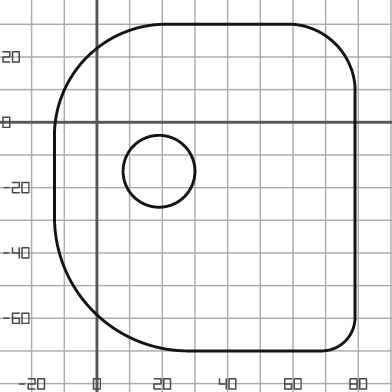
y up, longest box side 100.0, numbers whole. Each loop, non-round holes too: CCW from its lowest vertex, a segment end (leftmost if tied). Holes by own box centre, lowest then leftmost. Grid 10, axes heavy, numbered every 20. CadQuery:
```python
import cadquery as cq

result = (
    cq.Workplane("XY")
    .moveTo(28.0, -70.0)
    .lineTo(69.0, -70.0)
    .threePointArc((76.0, -67.0), (79.0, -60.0))
    .lineTo(79.0, 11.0)
    .threePointArc((73.0, 24.0), (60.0, 30.0))
    .lineTo(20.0, 30.0)
    .threePointArc((-3.0, 20.0), (-13.0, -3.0))
    .lineTo(-13.0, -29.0)
    .threePointArc((-1.0, -58.0), (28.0, -70.0))
    .close()
    .moveTo(19.0, -15.0)
    .circle(11.0)
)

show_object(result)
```